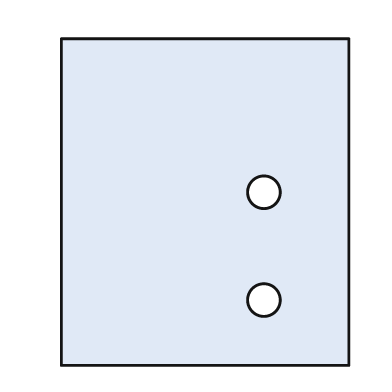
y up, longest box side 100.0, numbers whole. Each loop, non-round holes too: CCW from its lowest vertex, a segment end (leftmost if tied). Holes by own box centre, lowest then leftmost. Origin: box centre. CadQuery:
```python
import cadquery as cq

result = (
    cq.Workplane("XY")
    .moveTo(-44.0, -50.0)
    .lineTo(44.0, -50.0)
    .lineTo(44.0, 50.0)
    .lineTo(-44.0, 50.0)
    .close()
    .moveTo(18.0, -30.0)
    .circle(5.0)
    .moveTo(18.0, 3.0)
    .circle(5.0)
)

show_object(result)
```